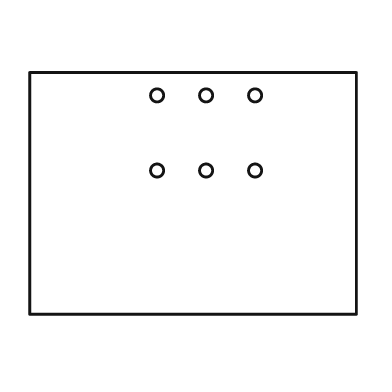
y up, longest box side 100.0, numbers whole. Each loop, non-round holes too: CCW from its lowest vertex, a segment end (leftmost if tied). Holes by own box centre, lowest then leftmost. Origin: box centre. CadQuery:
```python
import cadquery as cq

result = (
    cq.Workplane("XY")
    .moveTo(-50.0, -37.0)
    .lineTo(50.0, -37.0)
    .lineTo(50.0, 37.0)
    .lineTo(-50.0, 37.0)
    .close()
    .moveTo(-11.0, 7.0)
    .circle(2.0)
    .moveTo(4.0, 7.0)
    .circle(2.0)
    .moveTo(19.0, 7.0)
    .circle(2.0)
    .moveTo(-11.0, 30.0)
    .circle(2.0)
    .moveTo(4.0, 30.0)
    .circle(2.0)
    .moveTo(19.0, 30.0)
    .circle(2.0)
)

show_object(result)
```